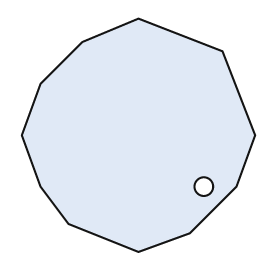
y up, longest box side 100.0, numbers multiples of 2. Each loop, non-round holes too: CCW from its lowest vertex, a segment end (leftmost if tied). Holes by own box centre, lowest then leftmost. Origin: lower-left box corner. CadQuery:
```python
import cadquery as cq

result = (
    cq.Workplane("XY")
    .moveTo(50.0, 0.0)
    .lineTo(72.0, 8.0)
    .lineTo(92.0, 28.0)
    .lineTo(100.0, 50.0)
    .lineTo(86.0, 86.0)
    .lineTo(50.0, 100.0)
    .lineTo(26.0, 90.0)
    .lineTo(8.0, 72.0)
    .lineTo(0.0, 50.0)
    .lineTo(8.0, 28.0)
    .lineTo(20.0, 12.0)
    .close()
    .moveTo(78.0, 28.0)
    .circle(4.0)
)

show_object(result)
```